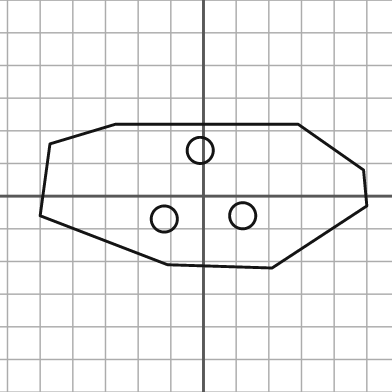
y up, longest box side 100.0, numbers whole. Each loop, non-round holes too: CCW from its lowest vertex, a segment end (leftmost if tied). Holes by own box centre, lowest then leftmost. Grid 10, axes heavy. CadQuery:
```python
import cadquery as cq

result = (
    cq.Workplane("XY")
    .moveTo(21.0, -22.0)
    .lineTo(50.0, -3.0)
    .lineTo(49.0, 8.0)
    .lineTo(29.0, 22.0)
    .lineTo(-27.0, 22.0)
    .lineTo(-47.0, 16.0)
    .lineTo(-50.0, -6.0)
    .lineTo(-11.0, -21.0)
    .close()
    .moveTo(-12.0, -7.0)
    .circle(4.0)
    .moveTo(12.0, -6.0)
    .circle(4.0)
    .moveTo(-1.0, 14.0)
    .circle(4.0)
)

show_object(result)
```